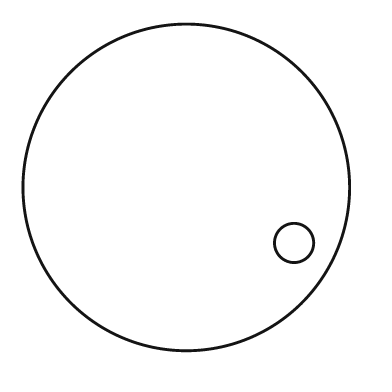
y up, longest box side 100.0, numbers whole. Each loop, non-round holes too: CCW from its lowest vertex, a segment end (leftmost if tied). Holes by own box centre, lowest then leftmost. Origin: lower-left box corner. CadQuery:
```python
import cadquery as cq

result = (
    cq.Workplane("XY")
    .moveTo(50.0, 50.0)
    .circle(50.0)
    .moveTo(83.0, 33.0)
    .circle(6.0)
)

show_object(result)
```